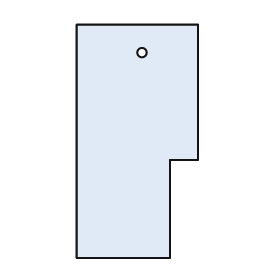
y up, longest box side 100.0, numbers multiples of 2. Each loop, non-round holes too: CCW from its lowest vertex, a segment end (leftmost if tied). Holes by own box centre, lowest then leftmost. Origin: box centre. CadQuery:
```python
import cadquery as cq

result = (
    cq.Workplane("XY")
    .moveTo(-26.0, -50.0)
    .lineTo(14.0, -50.0)
    .lineTo(14.0, -8.0)
    .lineTo(26.0, -8.0)
    .lineTo(26.0, 50.0)
    .lineTo(-26.0, 50.0)
    .close()
    .moveTo(2.0, 38.0)
    .circle(2.0)
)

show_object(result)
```